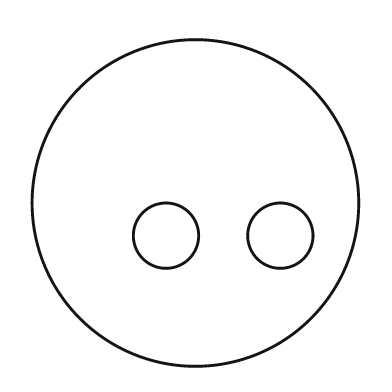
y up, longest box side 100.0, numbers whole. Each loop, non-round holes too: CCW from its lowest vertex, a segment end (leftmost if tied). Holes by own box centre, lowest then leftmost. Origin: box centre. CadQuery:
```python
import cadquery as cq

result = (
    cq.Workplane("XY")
    .moveTo(0.0, 0.0)
    .circle(50.0)
    .moveTo(-9.0, -10.0)
    .circle(10.0)
    .moveTo(26.0, -10.0)
    .circle(10.0)
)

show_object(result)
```